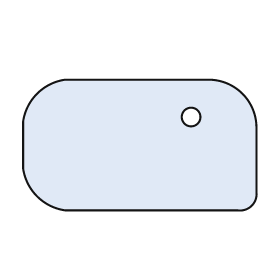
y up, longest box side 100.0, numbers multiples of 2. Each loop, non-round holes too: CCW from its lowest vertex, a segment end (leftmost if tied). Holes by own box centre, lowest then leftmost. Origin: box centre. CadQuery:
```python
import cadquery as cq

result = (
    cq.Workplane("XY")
    .moveTo(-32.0, -28.0)
    .lineTo(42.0, -28.0)
    .threePointArc((48.0, -26.0), (50.0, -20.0))
    .lineTo(50.0, 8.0)
    .threePointArc((44.0, 22.0), (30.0, 28.0))
    .lineTo(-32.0, 28.0)
    .threePointArc((-44.0, 22.0), (-50.0, 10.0))
    .lineTo(-50.0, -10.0)
    .threePointArc((-44.0, -22.0), (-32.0, -28.0))
    .close()
    .moveTo(22.0, 12.0)
    .circle(4.0)
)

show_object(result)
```